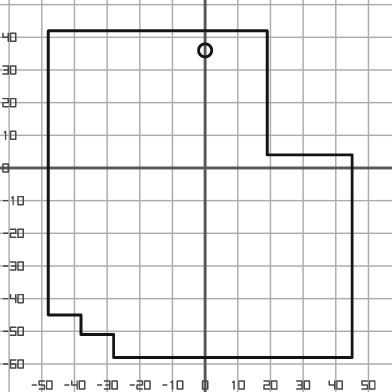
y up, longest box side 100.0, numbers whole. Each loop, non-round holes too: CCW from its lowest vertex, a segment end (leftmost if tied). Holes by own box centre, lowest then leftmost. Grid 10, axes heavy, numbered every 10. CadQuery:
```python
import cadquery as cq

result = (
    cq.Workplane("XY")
    .moveTo(-28.0, -58.0)
    .lineTo(45.0, -58.0)
    .lineTo(45.0, 4.0)
    .lineTo(19.0, 4.0)
    .lineTo(19.0, 42.0)
    .lineTo(-48.0, 42.0)
    .lineTo(-48.0, -45.0)
    .lineTo(-38.0, -45.0)
    .lineTo(-38.0, -51.0)
    .lineTo(-28.0, -51.0)
    .close()
    .moveTo(0.0, 36.0)
    .circle(2.0)
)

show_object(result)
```